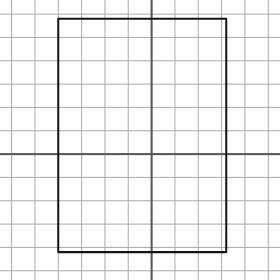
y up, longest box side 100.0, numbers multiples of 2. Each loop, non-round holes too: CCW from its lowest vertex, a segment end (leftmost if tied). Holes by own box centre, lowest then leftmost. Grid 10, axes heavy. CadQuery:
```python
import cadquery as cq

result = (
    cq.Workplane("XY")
    .moveTo(-40.0, -42.0)
    .lineTo(32.0, -42.0)
    .lineTo(32.0, 58.0)
    .lineTo(-40.0, 58.0)
    .close()
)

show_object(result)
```